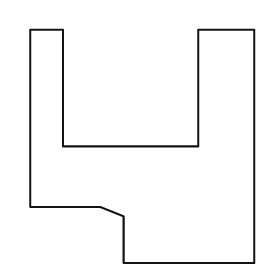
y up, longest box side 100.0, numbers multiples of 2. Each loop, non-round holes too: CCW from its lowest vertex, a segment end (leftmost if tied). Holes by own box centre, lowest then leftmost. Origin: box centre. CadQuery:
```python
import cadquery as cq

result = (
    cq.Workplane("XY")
    .moveTo(-8.0, -50.0)
    .lineTo(48.0, -50.0)
    .lineTo(48.0, 50.0)
    .lineTo(24.0, 50.0)
    .lineTo(24.0, 0.0)
    .lineTo(-34.0, 0.0)
    .lineTo(-34.0, 50.0)
    .lineTo(-48.0, 50.0)
    .lineTo(-48.0, -26.0)
    .lineTo(-18.0, -26.0)
    .lineTo(-8.0, -30.0)
    .close()
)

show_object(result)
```